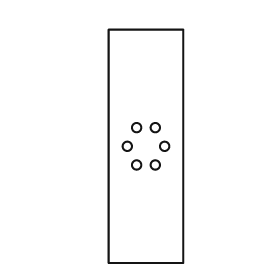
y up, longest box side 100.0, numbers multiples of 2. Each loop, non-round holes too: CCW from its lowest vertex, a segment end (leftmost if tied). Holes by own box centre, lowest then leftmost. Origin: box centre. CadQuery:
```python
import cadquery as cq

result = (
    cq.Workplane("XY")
    .moveTo(-16.0, -50.0)
    .lineTo(16.0, -50.0)
    .lineTo(16.0, 50.0)
    .lineTo(-16.0, 50.0)
    .close()
    .moveTo(-4.0, -8.0)
    .circle(2.0)
    .moveTo(4.0, -8.0)
    .circle(2.0)
    .moveTo(-8.0, 0.0)
    .circle(2.0)
    .moveTo(8.0, 0.0)
    .circle(2.0)
    .moveTo(-4.0, 8.0)
    .circle(2.0)
    .moveTo(4.0, 8.0)
    .circle(2.0)
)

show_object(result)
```